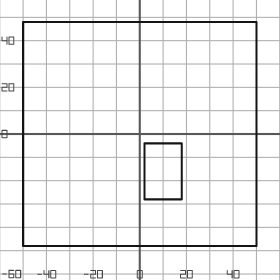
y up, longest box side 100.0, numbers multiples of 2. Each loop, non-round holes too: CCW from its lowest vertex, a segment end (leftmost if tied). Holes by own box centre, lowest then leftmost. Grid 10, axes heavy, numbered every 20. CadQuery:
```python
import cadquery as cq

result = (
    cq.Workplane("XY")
    .moveTo(-50.0, -48.0)
    .lineTo(50.0, -48.0)
    .lineTo(50.0, 48.0)
    .lineTo(-50.0, 48.0)
    .close()
    .moveTo(2.0, -28.0)
    .lineTo(18.0, -28.0)
    .lineTo(18.0, -4.0)
    .lineTo(2.0, -4.0)
    .close()
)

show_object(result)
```